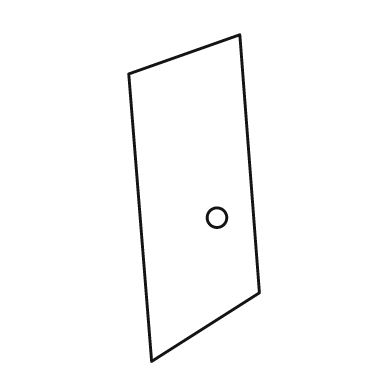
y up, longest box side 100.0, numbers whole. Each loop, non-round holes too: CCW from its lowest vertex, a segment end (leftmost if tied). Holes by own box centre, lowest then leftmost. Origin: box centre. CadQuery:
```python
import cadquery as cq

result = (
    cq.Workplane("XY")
    .moveTo(-13.0, -50.0)
    .lineTo(20.0, -29.0)
    .lineTo(14.0, 50.0)
    .lineTo(-20.0, 38.0)
    .close()
    .moveTo(7.0, -6.0)
    .circle(3.0)
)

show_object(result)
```